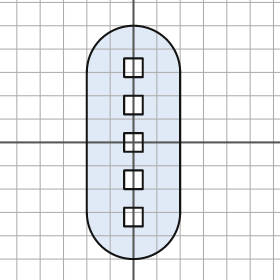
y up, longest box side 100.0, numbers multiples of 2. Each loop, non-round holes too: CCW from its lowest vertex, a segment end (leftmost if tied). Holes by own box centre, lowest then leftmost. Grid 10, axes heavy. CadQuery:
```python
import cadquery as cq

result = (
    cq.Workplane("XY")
    .moveTo(-20.0, -30.0)
    .threePointArc((0.0, -50.0), (20.0, -30.0))
    .lineTo(20.0, 30.0)
    .threePointArc((0.0, 50.0), (-20.0, 30.0))
    .close()
    .moveTo(-4.0, -36.0)
    .lineTo(4.0, -36.0)
    .lineTo(4.0, -28.0)
    .lineTo(-4.0, -28.0)
    .close()
    .moveTo(-4.0, -20.0)
    .lineTo(4.0, -20.0)
    .lineTo(4.0, -12.0)
    .lineTo(-4.0, -12.0)
    .close()
    .moveTo(-4.0, -4.0)
    .lineTo(4.0, -4.0)
    .lineTo(4.0, 4.0)
    .lineTo(-4.0, 4.0)
    .close()
    .moveTo(-4.0, 12.0)
    .lineTo(4.0, 12.0)
    .lineTo(4.0, 20.0)
    .lineTo(-4.0, 20.0)
    .close()
    .moveTo(-4.0, 28.0)
    .lineTo(4.0, 28.0)
    .lineTo(4.0, 36.0)
    .lineTo(-4.0, 36.0)
    .close()
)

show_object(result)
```